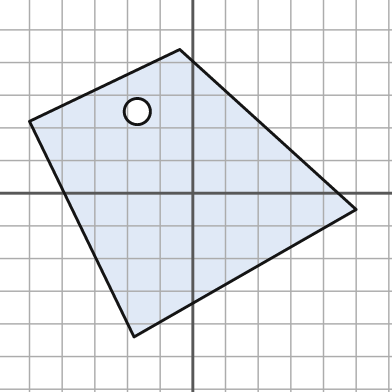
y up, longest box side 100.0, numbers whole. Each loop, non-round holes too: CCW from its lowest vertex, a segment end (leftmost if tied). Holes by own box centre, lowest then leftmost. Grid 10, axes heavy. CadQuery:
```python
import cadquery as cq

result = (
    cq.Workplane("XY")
    .moveTo(-18.0, -44.0)
    .lineTo(50.0, -5.0)
    .lineTo(-4.0, 44.0)
    .lineTo(-50.0, 22.0)
    .close()
    .moveTo(-17.0, 25.0)
    .circle(4.0)
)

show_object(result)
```